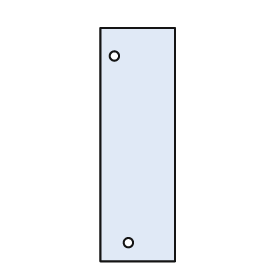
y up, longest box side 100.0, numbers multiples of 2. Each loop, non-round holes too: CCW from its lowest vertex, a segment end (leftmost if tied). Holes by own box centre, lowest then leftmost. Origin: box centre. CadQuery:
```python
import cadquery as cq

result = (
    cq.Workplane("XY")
    .moveTo(-16.0, -50.0)
    .lineTo(16.0, -50.0)
    .lineTo(16.0, 50.0)
    .lineTo(-16.0, 50.0)
    .close()
    .moveTo(-4.0, -42.0)
    .circle(2.0)
    .moveTo(-10.0, 38.0)
    .circle(2.0)
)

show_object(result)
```